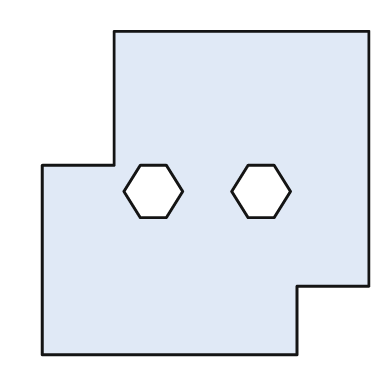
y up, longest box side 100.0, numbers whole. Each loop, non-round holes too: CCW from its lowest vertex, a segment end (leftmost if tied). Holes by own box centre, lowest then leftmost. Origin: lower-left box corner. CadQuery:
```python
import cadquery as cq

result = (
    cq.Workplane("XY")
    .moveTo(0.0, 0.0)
    .lineTo(78.0, 0.0)
    .lineTo(78.0, 21.0)
    .lineTo(100.0, 21.0)
    .lineTo(100.0, 99.0)
    .lineTo(22.0, 99.0)
    .lineTo(22.0, 58.0)
    .lineTo(0.0, 58.0)
    .close()
    .moveTo(30.0, 42.0)
    .lineTo(38.0, 42.0)
    .lineTo(43.0, 50.0)
    .lineTo(38.0, 58.0)
    .lineTo(30.0, 58.0)
    .lineTo(25.0, 50.0)
    .close()
    .moveTo(63.0, 42.0)
    .lineTo(71.0, 42.0)
    .lineTo(76.0, 50.0)
    .lineTo(71.0, 58.0)
    .lineTo(63.0, 58.0)
    .lineTo(58.0, 50.0)
    .close()
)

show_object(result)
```